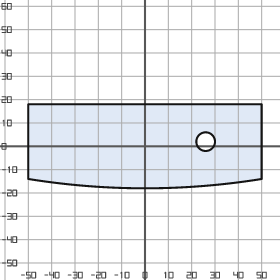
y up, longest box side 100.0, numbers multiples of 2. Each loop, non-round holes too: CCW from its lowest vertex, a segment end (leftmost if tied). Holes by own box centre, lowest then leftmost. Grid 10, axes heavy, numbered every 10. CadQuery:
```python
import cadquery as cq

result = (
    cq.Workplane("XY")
    .moveTo(-50.0, -14.0)
    .threePointArc((0.0, -18.0), (50.0, -14.0))
    .lineTo(50.0, 18.0)
    .lineTo(-50.0, 18.0)
    .close()
    .moveTo(26.0, 2.0)
    .circle(4.0)
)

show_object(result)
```